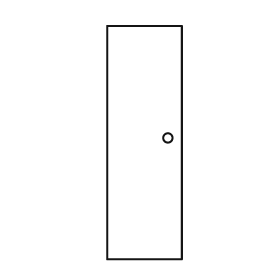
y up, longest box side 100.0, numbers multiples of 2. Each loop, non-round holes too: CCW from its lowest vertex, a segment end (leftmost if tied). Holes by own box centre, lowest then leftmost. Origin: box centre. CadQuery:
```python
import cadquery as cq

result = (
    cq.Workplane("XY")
    .moveTo(-16.0, -50.0)
    .lineTo(16.0, -50.0)
    .lineTo(16.0, 50.0)
    .lineTo(-16.0, 50.0)
    .close()
    .moveTo(10.0, 2.0)
    .circle(2.0)
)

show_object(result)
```